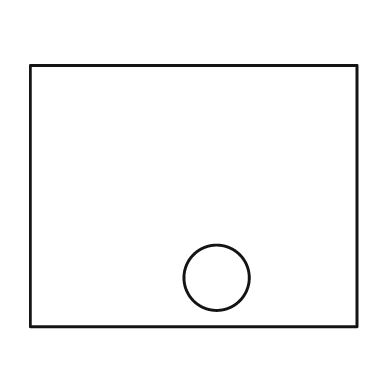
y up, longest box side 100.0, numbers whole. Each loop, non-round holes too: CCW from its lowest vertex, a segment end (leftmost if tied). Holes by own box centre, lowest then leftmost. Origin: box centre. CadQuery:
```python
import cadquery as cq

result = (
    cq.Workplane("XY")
    .moveTo(-50.0, -40.0)
    .lineTo(50.0, -40.0)
    .lineTo(50.0, 40.0)
    .lineTo(-50.0, 40.0)
    .close()
    .moveTo(7.0, -25.0)
    .circle(10.0)
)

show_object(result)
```